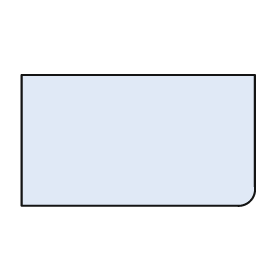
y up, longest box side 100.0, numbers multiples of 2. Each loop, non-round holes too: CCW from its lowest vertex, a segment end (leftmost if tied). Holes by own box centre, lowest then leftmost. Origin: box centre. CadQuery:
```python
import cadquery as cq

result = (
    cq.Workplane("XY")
    .moveTo(-50.0, -28.0)
    .lineTo(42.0, -28.0)
    .threePointArc((48.0, -26.0), (50.0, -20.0))
    .lineTo(50.0, 28.0)
    .lineTo(-50.0, 28.0)
    .close()
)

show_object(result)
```